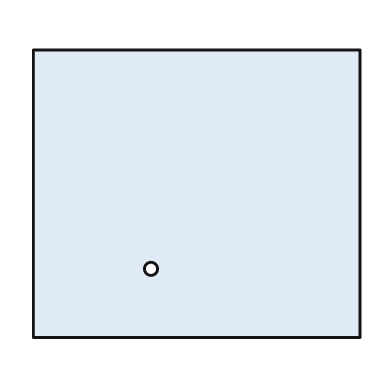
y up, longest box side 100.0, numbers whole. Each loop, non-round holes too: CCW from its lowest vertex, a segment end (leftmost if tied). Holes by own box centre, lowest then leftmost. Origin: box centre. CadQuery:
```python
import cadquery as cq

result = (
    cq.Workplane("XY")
    .moveTo(-50.0, -44.0)
    .lineTo(50.0, -44.0)
    .lineTo(50.0, 44.0)
    .lineTo(-50.0, 44.0)
    .close()
    .moveTo(-14.0, -23.0)
    .circle(2.0)
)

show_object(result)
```